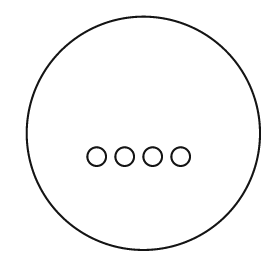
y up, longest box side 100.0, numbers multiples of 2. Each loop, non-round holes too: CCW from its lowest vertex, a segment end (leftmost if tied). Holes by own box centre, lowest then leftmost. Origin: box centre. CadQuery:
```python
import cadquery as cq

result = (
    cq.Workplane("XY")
    .moveTo(0.0, 0.0)
    .circle(50.0)
    .moveTo(-20.0, -10.0)
    .circle(4.0)
    .moveTo(-8.0, -10.0)
    .circle(4.0)
    .moveTo(4.0, -10.0)
    .circle(4.0)
    .moveTo(16.0, -10.0)
    .circle(4.0)
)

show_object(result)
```